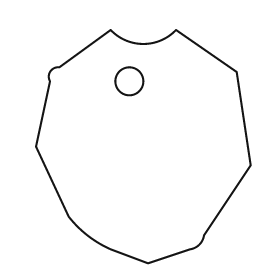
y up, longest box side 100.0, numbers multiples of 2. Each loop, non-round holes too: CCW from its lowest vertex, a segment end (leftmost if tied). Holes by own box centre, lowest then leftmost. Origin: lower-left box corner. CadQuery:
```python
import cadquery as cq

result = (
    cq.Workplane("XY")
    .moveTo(48.0, 0.0)
    .lineTo(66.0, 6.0)
    .threePointArc((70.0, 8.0), (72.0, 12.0))
    .lineTo(92.0, 42.0)
    .lineTo(86.0, 82.0)
    .lineTo(60.0, 100.0)
    .threePointArc((46.0, 94.0), (32.0, 100.0))
    .lineTo(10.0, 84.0)
    .threePointArc((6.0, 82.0), (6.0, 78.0))
    .lineTo(0.0, 50.0)
    .lineTo(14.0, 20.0)
    .threePointArc((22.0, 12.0), (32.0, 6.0))
    .close()
    .moveTo(40.0, 78.0)
    .circle(6.0)
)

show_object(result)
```